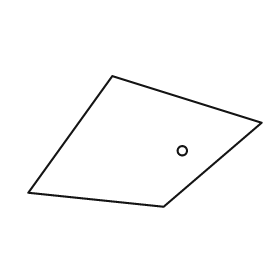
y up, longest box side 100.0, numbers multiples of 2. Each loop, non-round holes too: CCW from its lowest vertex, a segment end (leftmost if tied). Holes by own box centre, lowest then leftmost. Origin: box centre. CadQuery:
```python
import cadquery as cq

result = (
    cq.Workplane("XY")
    .moveTo(8.0, -28.0)
    .lineTo(50.0, 8.0)
    .lineTo(-14.0, 28.0)
    .lineTo(-50.0, -22.0)
    .close()
    .moveTo(16.0, -4.0)
    .circle(2.0)
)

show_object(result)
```